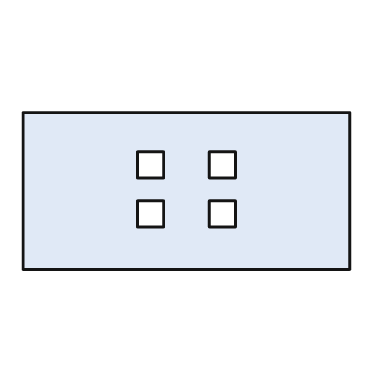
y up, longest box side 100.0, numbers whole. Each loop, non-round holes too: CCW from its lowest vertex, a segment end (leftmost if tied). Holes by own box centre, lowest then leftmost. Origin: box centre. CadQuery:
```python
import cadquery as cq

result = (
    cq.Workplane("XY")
    .moveTo(-50.0, -24.0)
    .lineTo(50.0, -24.0)
    .lineTo(50.0, 24.0)
    .lineTo(-50.0, 24.0)
    .close()
    .moveTo(-15.0, -11.0)
    .lineTo(-7.0, -11.0)
    .lineTo(-7.0, -3.0)
    .lineTo(-15.0, -3.0)
    .close()
    .moveTo(7.0, -11.0)
    .lineTo(15.0, -11.0)
    .lineTo(15.0, -3.0)
    .lineTo(7.0, -3.0)
    .close()
    .moveTo(-15.0, 4.0)
    .lineTo(-7.0, 4.0)
    .lineTo(-7.0, 12.0)
    .lineTo(-15.0, 12.0)
    .close()
    .moveTo(7.0, 4.0)
    .lineTo(15.0, 4.0)
    .lineTo(15.0, 12.0)
    .lineTo(7.0, 12.0)
    .close()
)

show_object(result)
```